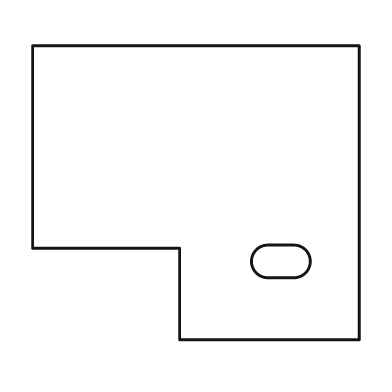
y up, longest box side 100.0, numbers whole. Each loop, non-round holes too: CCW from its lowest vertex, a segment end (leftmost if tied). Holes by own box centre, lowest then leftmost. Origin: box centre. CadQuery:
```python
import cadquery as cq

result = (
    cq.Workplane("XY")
    .moveTo(-5.0, -45.0)
    .lineTo(50.0, -45.0)
    .lineTo(50.0, 45.0)
    .lineTo(-50.0, 45.0)
    .lineTo(-50.0, -17.0)
    .lineTo(-5.0, -17.0)
    .close()
    .moveTo(22.0, -26.0)
    .lineTo(30.0, -26.0)
    .threePointArc((35.0, -21.0), (30.0, -16.0))
    .lineTo(22.0, -16.0)
    .threePointArc((17.0, -21.0), (22.0, -26.0))
    .close()
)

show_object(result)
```